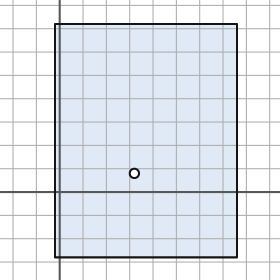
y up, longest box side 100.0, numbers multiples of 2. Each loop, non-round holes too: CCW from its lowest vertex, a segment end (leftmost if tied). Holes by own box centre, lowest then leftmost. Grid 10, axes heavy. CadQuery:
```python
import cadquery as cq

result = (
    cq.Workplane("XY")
    .moveTo(-2.0, -28.0)
    .lineTo(76.0, -28.0)
    .lineTo(76.0, 72.0)
    .lineTo(-2.0, 72.0)
    .close()
    .moveTo(32.0, 8.0)
    .circle(2.0)
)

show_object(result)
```